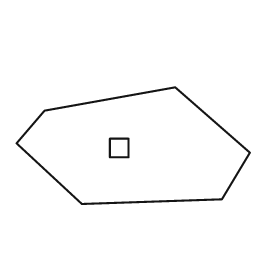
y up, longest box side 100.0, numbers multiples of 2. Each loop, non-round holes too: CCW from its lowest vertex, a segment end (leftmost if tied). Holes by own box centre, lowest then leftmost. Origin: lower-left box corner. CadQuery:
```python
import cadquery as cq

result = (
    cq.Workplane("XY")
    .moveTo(28.0, 0.0)
    .lineTo(88.0, 2.0)
    .lineTo(100.0, 22.0)
    .lineTo(68.0, 50.0)
    .lineTo(12.0, 40.0)
    .lineTo(0.0, 26.0)
    .close()
    .moveTo(40.0, 20.0)
    .lineTo(48.0, 20.0)
    .lineTo(48.0, 28.0)
    .lineTo(40.0, 28.0)
    .close()
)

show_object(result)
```